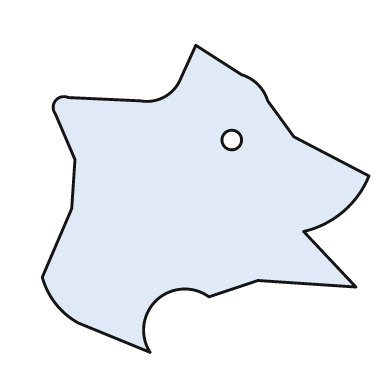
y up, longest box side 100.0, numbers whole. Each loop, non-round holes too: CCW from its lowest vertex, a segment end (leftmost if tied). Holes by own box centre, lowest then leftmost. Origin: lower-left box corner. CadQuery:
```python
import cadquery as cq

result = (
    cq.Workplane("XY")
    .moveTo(33.0, 0.0)
    .threePointArc((35.0, 16.0), (51.0, 17.0))
    .lineTo(66.0, 22.0)
    .lineTo(96.0, 20.0)
    .lineTo(80.0, 37.0)
    .threePointArc((92.0, 43.0), (100.0, 54.0))
    .lineTo(77.0, 66.0)
    .lineTo(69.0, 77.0)
    .threePointArc((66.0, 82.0), (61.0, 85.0))
    .lineTo(47.0, 94.0)
    .lineTo(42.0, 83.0)
    .threePointArc((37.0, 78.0), (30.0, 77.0))
    .lineTo(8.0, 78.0)
    .threePointArc((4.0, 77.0), (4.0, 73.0))
    .lineTo(10.0, 59.0)
    .lineTo(9.0, 44.0)
    .lineTo(0.0, 23.0)
    .threePointArc((4.0, 15.0), (11.0, 9.0))
    .close()
    .moveTo(58.0, 65.0)
    .circle(3.0)
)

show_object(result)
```